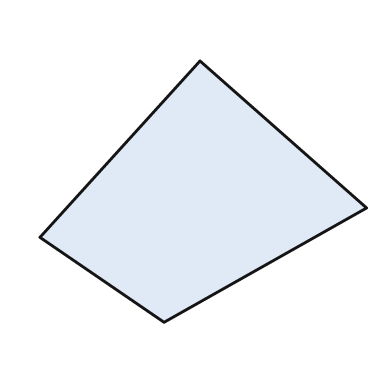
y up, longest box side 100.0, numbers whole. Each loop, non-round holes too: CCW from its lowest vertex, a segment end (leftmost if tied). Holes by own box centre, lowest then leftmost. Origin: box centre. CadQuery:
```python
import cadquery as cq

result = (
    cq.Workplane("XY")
    .moveTo(-12.0, -40.0)
    .lineTo(50.0, -5.0)
    .lineTo(-1.0, 40.0)
    .lineTo(-50.0, -14.0)
    .close()
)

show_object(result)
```